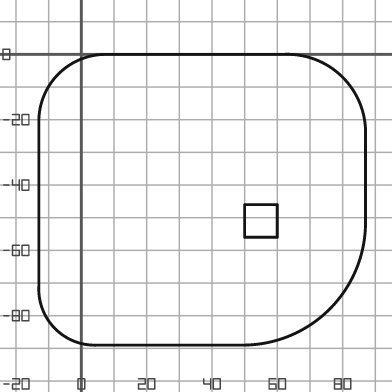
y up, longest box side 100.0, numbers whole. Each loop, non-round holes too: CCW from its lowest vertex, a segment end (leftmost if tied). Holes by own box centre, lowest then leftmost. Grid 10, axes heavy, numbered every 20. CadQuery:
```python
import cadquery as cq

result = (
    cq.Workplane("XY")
    .moveTo(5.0, -89.0)
    .lineTo(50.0, -89.0)
    .threePointArc((76.0, -78.0), (87.0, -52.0))
    .lineTo(87.0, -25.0)
    .threePointArc((80.0, -7.0), (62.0, 0.0))
    .lineTo(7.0, 0.0)
    .threePointArc((-7.0, -6.0), (-13.0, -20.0))
    .lineTo(-13.0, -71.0)
    .threePointArc((-8.0, -84.0), (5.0, -89.0))
    .close()
    .moveTo(50.0, -56.0)
    .lineTo(60.0, -56.0)
    .lineTo(60.0, -46.0)
    .lineTo(50.0, -46.0)
    .close()
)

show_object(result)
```